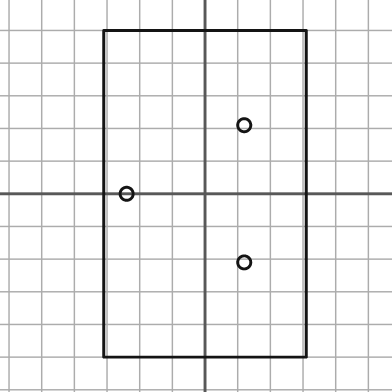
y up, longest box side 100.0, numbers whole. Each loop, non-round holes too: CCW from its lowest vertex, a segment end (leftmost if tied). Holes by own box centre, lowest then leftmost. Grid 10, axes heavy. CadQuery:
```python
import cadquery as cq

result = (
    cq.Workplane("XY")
    .moveTo(-31.0, -50.0)
    .lineTo(31.0, -50.0)
    .lineTo(31.0, 50.0)
    .lineTo(-31.0, 50.0)
    .close()
    .moveTo(12.0, -21.0)
    .circle(2.0)
    .moveTo(-24.0, 0.0)
    .circle(2.0)
    .moveTo(12.0, 21.0)
    .circle(2.0)
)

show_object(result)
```